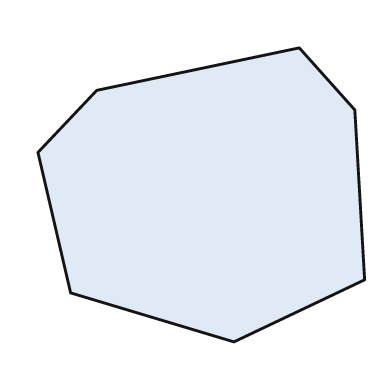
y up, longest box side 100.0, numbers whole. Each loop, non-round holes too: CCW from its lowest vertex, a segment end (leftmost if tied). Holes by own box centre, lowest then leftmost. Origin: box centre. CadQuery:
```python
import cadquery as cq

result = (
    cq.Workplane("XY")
    .moveTo(10.0, -45.0)
    .lineTo(50.0, -26.0)
    .lineTo(47.0, 26.0)
    .lineTo(30.0, 45.0)
    .lineTo(-32.0, 32.0)
    .lineTo(-50.0, 13.0)
    .lineTo(-40.0, -30.0)
    .close()
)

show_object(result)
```